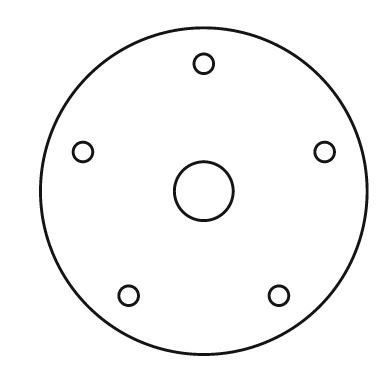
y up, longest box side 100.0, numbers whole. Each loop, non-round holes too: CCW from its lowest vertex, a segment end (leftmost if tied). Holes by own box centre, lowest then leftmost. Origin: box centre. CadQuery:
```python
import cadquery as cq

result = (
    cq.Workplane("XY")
    .moveTo(0.0, 0.0)
    .circle(50.0)
    .moveTo(-23.0, -32.0)
    .circle(3.0)
    .moveTo(23.0, -32.0)
    .circle(3.0)
    .moveTo(0.0, 0.0)
    .circle(9.0)
    .moveTo(-37.0, 12.0)
    .circle(3.0)
    .moveTo(37.0, 12.0)
    .circle(3.0)
    .moveTo(0.0, 39.0)
    .circle(3.0)
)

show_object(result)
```